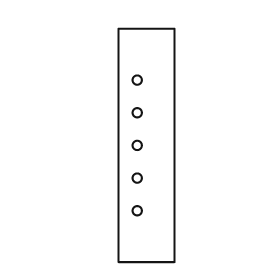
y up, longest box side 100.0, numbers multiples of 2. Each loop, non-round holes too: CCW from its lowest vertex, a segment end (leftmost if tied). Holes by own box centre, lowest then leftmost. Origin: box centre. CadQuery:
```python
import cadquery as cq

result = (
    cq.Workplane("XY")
    .moveTo(-12.0, -50.0)
    .lineTo(12.0, -50.0)
    .lineTo(12.0, 50.0)
    .lineTo(-12.0, 50.0)
    .close()
    .moveTo(-4.0, -28.0)
    .circle(2.0)
    .moveTo(-4.0, -14.0)
    .circle(2.0)
    .moveTo(-4.0, 0.0)
    .circle(2.0)
    .moveTo(-4.0, 14.0)
    .circle(2.0)
    .moveTo(-4.0, 28.0)
    .circle(2.0)
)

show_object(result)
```